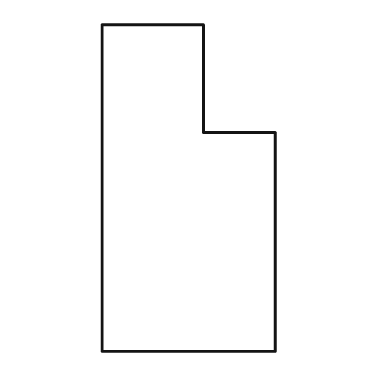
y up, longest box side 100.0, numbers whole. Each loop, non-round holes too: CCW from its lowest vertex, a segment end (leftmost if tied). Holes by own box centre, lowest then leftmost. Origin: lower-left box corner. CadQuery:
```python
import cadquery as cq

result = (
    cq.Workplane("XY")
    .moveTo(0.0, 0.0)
    .lineTo(53.0, 0.0)
    .lineTo(53.0, 67.0)
    .lineTo(31.0, 67.0)
    .lineTo(31.0, 100.0)
    .lineTo(0.0, 100.0)
    .close()
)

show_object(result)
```